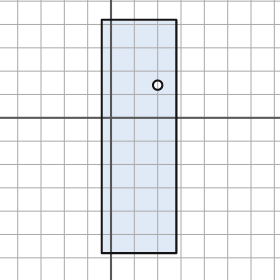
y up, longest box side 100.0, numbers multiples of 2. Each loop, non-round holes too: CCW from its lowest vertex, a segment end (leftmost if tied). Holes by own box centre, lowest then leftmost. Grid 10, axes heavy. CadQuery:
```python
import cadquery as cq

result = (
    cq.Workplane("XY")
    .moveTo(-4.0, -58.0)
    .lineTo(28.0, -58.0)
    .lineTo(28.0, 42.0)
    .lineTo(-4.0, 42.0)
    .close()
    .moveTo(20.0, 14.0)
    .circle(2.0)
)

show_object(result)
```